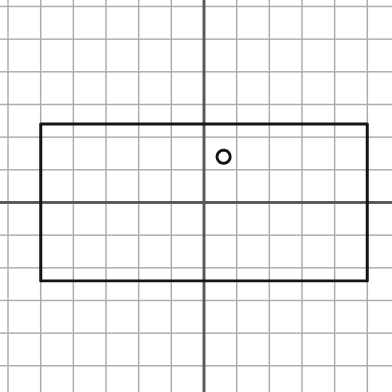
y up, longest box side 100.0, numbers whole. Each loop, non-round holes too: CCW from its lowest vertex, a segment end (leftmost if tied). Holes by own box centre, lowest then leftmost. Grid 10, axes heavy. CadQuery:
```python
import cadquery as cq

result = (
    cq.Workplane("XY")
    .moveTo(-50.0, -24.0)
    .lineTo(50.0, -24.0)
    .lineTo(50.0, 24.0)
    .lineTo(-50.0, 24.0)
    .close()
    .moveTo(6.0, 14.0)
    .circle(2.0)
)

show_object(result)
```